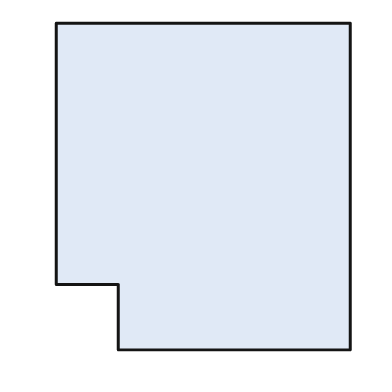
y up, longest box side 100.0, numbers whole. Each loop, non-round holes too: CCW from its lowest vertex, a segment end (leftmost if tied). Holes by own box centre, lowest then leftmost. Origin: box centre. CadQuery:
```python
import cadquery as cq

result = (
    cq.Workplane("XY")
    .moveTo(-26.0, -50.0)
    .lineTo(45.0, -50.0)
    .lineTo(45.0, 50.0)
    .lineTo(-45.0, 50.0)
    .lineTo(-45.0, -30.0)
    .lineTo(-26.0, -30.0)
    .close()
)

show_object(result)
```